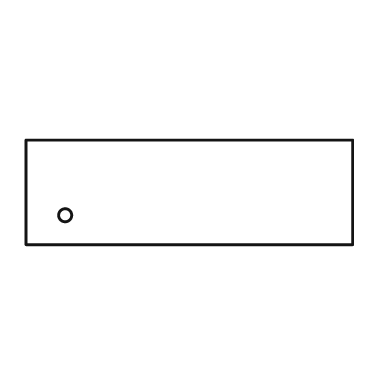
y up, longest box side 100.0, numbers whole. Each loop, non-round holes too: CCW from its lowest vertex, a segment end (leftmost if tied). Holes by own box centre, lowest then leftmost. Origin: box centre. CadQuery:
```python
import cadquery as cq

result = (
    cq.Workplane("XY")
    .moveTo(-50.0, -16.0)
    .lineTo(50.0, -16.0)
    .lineTo(50.0, 16.0)
    .lineTo(-50.0, 16.0)
    .close()
    .moveTo(-38.0, -7.0)
    .circle(2.0)
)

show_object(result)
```